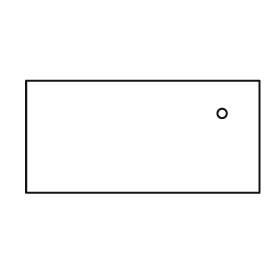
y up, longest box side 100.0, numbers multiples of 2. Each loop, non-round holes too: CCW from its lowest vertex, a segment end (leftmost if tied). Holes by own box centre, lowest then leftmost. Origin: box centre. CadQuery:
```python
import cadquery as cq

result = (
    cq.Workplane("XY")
    .moveTo(-50.0, -24.0)
    .lineTo(50.0, -24.0)
    .lineTo(50.0, 24.0)
    .lineTo(-50.0, 24.0)
    .close()
    .moveTo(34.0, 10.0)
    .circle(2.0)
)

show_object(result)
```